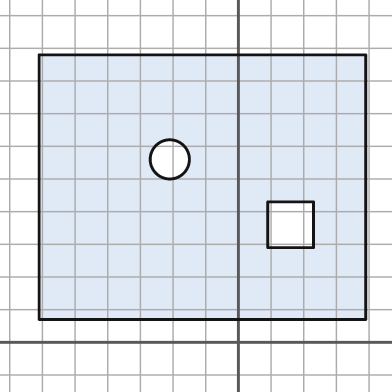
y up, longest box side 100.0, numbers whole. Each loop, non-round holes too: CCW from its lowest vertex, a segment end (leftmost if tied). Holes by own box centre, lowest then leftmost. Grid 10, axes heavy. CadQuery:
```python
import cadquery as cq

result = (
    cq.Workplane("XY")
    .moveTo(-61.0, 7.0)
    .lineTo(39.0, 7.0)
    .lineTo(39.0, 88.0)
    .lineTo(-61.0, 88.0)
    .close()
    .moveTo(9.0, 29.0)
    .lineTo(23.0, 29.0)
    .lineTo(23.0, 43.0)
    .lineTo(9.0, 43.0)
    .close()
    .moveTo(-21.0, 56.0)
    .circle(6.0)
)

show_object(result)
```